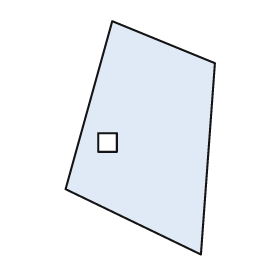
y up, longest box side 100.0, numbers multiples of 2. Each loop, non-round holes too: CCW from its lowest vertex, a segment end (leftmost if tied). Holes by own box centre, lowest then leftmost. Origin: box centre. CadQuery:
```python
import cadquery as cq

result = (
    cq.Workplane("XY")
    .moveTo(26.0, -50.0)
    .lineTo(32.0, 32.0)
    .lineTo(-12.0, 50.0)
    .lineTo(-32.0, -22.0)
    .close()
    .moveTo(-18.0, -6.0)
    .lineTo(-10.0, -6.0)
    .lineTo(-10.0, 2.0)
    .lineTo(-18.0, 2.0)
    .close()
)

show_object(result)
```